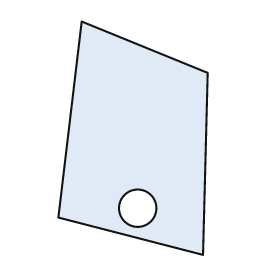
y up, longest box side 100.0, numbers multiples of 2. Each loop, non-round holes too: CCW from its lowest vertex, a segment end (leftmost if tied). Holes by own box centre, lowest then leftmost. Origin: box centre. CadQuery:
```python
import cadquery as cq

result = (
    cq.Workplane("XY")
    .moveTo(30.0, -50.0)
    .lineTo(32.0, 28.0)
    .lineTo(-22.0, 50.0)
    .lineTo(-32.0, -34.0)
    .close()
    .moveTo(2.0, -30.0)
    .circle(8.0)
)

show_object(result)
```